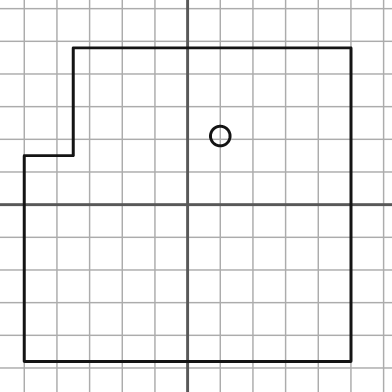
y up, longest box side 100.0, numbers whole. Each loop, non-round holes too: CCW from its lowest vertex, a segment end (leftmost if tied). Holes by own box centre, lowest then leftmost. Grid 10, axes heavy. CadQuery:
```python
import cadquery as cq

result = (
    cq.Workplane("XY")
    .moveTo(-50.0, -48.0)
    .lineTo(50.0, -48.0)
    .lineTo(50.0, 48.0)
    .lineTo(-35.0, 48.0)
    .lineTo(-35.0, 15.0)
    .lineTo(-50.0, 15.0)
    .close()
    .moveTo(10.0, 21.0)
    .circle(3.0)
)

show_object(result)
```